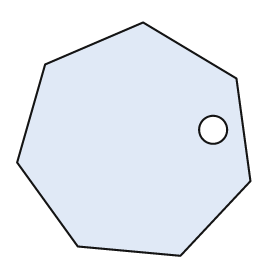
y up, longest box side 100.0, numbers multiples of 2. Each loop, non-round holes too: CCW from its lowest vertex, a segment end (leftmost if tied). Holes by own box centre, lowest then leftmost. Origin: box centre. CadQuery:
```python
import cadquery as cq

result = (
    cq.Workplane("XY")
    .moveTo(20.0, -50.0)
    .lineTo(50.0, -18.0)
    .lineTo(44.0, 26.0)
    .lineTo(4.0, 50.0)
    .lineTo(-38.0, 32.0)
    .lineTo(-50.0, -10.0)
    .lineTo(-24.0, -46.0)
    .close()
    .moveTo(34.0, 4.0)
    .circle(6.0)
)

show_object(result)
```